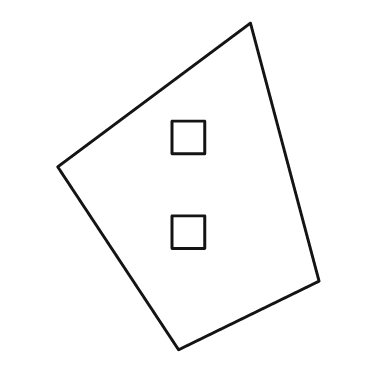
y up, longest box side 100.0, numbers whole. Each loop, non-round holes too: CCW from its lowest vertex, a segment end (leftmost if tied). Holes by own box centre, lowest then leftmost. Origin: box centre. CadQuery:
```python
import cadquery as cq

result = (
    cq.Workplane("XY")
    .moveTo(-3.0, -50.0)
    .lineTo(40.0, -29.0)
    .lineTo(19.0, 50.0)
    .lineTo(-40.0, 6.0)
    .close()
    .moveTo(-5.0, -19.0)
    .lineTo(5.0, -19.0)
    .lineTo(5.0, -9.0)
    .lineTo(-5.0, -9.0)
    .close()
    .moveTo(-5.0, 10.0)
    .lineTo(5.0, 10.0)
    .lineTo(5.0, 20.0)
    .lineTo(-5.0, 20.0)
    .close()
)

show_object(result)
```